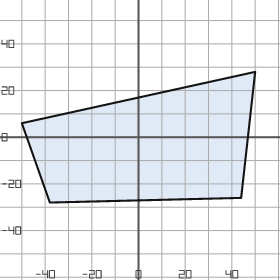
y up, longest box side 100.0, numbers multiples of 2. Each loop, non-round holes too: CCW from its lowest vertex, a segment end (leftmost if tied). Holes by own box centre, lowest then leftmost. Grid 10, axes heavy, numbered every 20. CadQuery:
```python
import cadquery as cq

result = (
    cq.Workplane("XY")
    .moveTo(-38.0, -28.0)
    .lineTo(44.0, -26.0)
    .lineTo(50.0, 28.0)
    .lineTo(-50.0, 6.0)
    .close()
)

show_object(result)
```